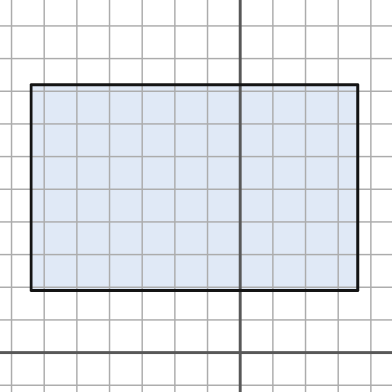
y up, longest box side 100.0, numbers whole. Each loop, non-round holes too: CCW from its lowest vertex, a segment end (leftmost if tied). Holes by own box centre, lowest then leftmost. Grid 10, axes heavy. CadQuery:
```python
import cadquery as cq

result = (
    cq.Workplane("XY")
    .moveTo(-64.0, 19.0)
    .lineTo(36.0, 19.0)
    .lineTo(36.0, 82.0)
    .lineTo(-64.0, 82.0)
    .close()
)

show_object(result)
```